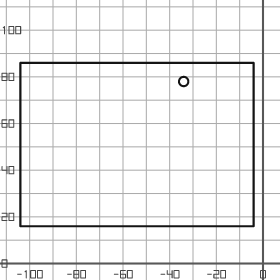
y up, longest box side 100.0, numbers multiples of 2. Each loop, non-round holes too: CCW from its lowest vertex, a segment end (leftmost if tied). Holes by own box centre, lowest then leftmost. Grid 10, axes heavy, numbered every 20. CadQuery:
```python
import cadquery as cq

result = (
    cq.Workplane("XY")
    .moveTo(-104.0, 16.0)
    .lineTo(-4.0, 16.0)
    .lineTo(-4.0, 86.0)
    .lineTo(-104.0, 86.0)
    .close()
    .moveTo(-34.0, 78.0)
    .circle(2.0)
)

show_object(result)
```